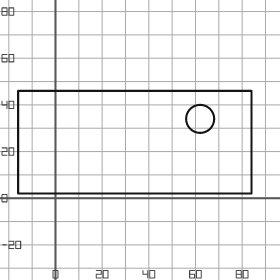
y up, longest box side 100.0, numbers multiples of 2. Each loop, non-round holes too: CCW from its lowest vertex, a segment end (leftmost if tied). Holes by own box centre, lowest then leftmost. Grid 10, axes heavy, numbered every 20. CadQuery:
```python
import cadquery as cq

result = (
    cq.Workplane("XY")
    .moveTo(-16.0, 2.0)
    .lineTo(84.0, 2.0)
    .lineTo(84.0, 46.0)
    .lineTo(-16.0, 46.0)
    .close()
    .moveTo(62.0, 34.0)
    .circle(6.0)
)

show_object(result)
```